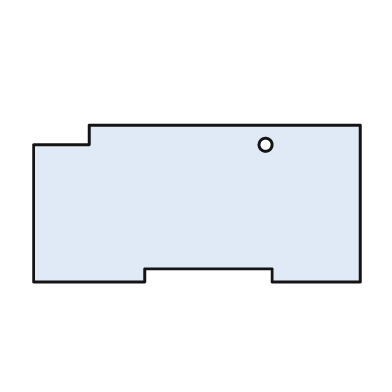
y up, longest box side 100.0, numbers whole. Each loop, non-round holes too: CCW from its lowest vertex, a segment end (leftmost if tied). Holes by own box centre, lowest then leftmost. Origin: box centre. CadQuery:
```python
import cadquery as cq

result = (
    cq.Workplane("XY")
    .moveTo(-50.0, -24.0)
    .lineTo(-16.0, -24.0)
    .lineTo(-16.0, -20.0)
    .lineTo(23.0, -20.0)
    .lineTo(23.0, -24.0)
    .lineTo(50.0, -24.0)
    .lineTo(50.0, 24.0)
    .lineTo(-33.0, 24.0)
    .lineTo(-33.0, 18.0)
    .lineTo(-50.0, 18.0)
    .close()
    .moveTo(21.0, 18.0)
    .circle(2.0)
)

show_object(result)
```